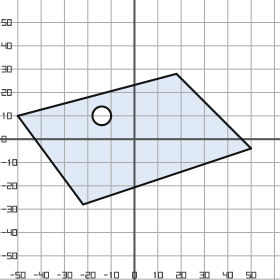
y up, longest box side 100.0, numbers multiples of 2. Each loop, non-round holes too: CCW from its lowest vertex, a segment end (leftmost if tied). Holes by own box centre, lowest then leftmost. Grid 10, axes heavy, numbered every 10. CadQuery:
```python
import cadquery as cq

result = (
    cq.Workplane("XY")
    .moveTo(-22.0, -28.0)
    .lineTo(50.0, -4.0)
    .lineTo(18.0, 28.0)
    .lineTo(-50.0, 10.0)
    .close()
    .moveTo(-14.0, 10.0)
    .circle(4.0)
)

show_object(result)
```